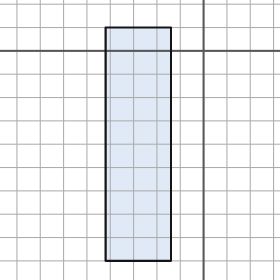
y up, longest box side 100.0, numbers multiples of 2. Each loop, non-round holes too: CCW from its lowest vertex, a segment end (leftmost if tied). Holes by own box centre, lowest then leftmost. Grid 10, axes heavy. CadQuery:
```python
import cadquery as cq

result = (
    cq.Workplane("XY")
    .moveTo(-42.0, -90.0)
    .lineTo(-14.0, -90.0)
    .lineTo(-14.0, 10.0)
    .lineTo(-42.0, 10.0)
    .close()
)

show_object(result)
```